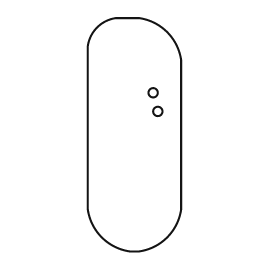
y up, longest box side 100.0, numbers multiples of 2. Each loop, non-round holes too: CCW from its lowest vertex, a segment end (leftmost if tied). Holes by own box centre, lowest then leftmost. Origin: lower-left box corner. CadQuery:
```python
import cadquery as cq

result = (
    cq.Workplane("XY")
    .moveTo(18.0, 0.0)
    .lineTo(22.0, 0.0)
    .threePointArc((34.0, 6.0), (40.0, 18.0))
    .lineTo(40.0, 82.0)
    .threePointArc((34.0, 94.0), (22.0, 100.0))
    .lineTo(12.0, 100.0)
    .threePointArc((4.0, 96.0), (0.0, 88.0))
    .lineTo(0.0, 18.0)
    .threePointArc((6.0, 6.0), (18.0, 0.0))
    .close()
    .moveTo(30.0, 60.0)
    .circle(2.0)
    .moveTo(28.0, 68.0)
    .circle(2.0)
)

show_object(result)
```